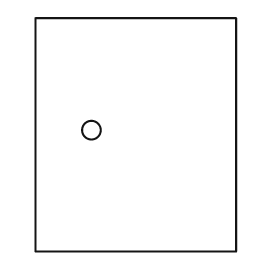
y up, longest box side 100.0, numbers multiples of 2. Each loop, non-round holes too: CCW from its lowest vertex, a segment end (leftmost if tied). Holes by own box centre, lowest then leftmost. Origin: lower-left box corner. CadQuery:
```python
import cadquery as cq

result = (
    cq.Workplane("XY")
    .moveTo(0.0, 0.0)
    .lineTo(86.0, 0.0)
    .lineTo(86.0, 100.0)
    .lineTo(0.0, 100.0)
    .close()
    .moveTo(24.0, 52.0)
    .circle(4.0)
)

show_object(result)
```